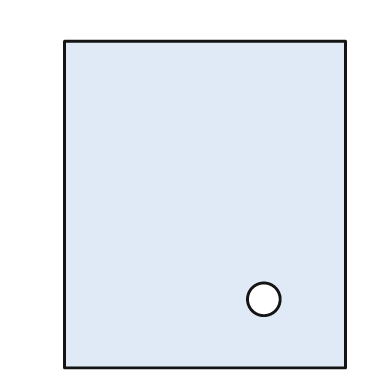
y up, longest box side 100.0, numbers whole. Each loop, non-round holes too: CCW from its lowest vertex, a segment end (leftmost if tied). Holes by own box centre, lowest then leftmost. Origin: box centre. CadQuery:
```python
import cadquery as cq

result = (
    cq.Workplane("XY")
    .moveTo(-43.0, -50.0)
    .lineTo(43.0, -50.0)
    .lineTo(43.0, 50.0)
    .lineTo(-43.0, 50.0)
    .close()
    .moveTo(18.0, -29.0)
    .circle(5.0)
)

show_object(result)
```